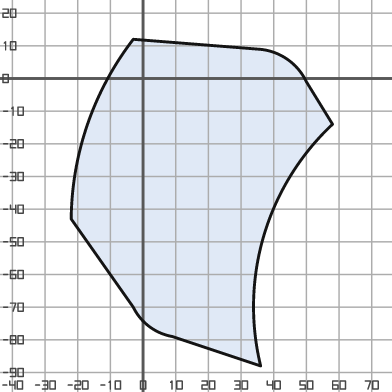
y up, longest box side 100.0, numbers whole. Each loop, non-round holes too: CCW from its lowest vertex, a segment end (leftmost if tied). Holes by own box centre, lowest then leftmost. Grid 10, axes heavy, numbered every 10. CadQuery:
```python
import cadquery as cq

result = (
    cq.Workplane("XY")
    .moveTo(36.0, -88.0)
    .threePointArc((37.0, -48.0), (58.0, -14.0))
    .lineTo(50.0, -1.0)
    .threePointArc((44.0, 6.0), (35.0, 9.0))
    .lineTo(-3.0, 12.0)
    .threePointArc((-17.0, -14.0), (-22.0, -43.0))
    .lineTo(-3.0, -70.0)
    .threePointArc((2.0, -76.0), (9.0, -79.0))
    .close()
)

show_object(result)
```